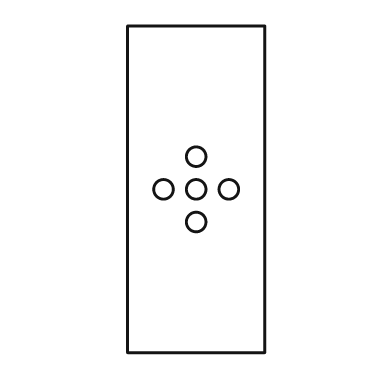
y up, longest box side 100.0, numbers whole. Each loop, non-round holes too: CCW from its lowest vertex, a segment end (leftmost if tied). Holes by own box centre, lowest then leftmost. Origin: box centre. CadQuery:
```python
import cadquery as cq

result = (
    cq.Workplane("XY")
    .moveTo(-21.0, -50.0)
    .lineTo(21.0, -50.0)
    .lineTo(21.0, 50.0)
    .lineTo(-21.0, 50.0)
    .close()
    .moveTo(0.0, -10.0)
    .circle(3.0)
    .moveTo(-10.0, 0.0)
    .circle(3.0)
    .moveTo(0.0, 0.0)
    .circle(3.0)
    .moveTo(10.0, 0.0)
    .circle(3.0)
    .moveTo(0.0, 10.0)
    .circle(3.0)
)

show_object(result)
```